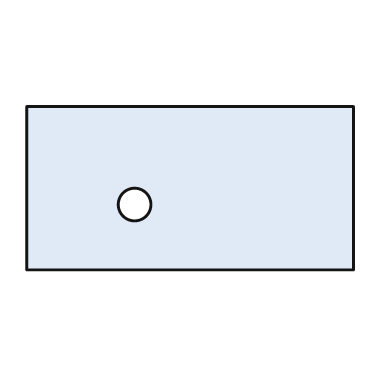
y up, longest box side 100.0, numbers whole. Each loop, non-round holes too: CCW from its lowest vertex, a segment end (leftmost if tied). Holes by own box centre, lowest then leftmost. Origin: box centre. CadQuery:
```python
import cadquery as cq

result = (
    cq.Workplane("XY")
    .moveTo(-50.0, -25.0)
    .lineTo(50.0, -25.0)
    .lineTo(50.0, 25.0)
    .lineTo(-50.0, 25.0)
    .close()
    .moveTo(-17.0, -5.0)
    .circle(5.0)
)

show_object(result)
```